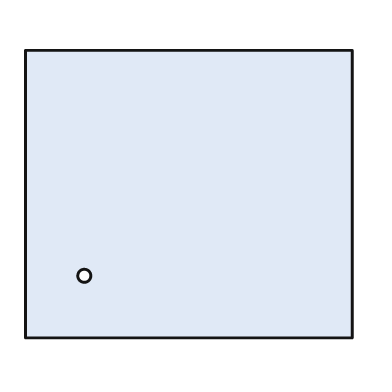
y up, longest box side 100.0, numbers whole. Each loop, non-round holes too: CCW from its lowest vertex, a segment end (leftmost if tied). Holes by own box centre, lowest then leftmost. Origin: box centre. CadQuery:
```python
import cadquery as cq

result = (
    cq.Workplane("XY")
    .moveTo(-50.0, -44.0)
    .lineTo(50.0, -44.0)
    .lineTo(50.0, 44.0)
    .lineTo(-50.0, 44.0)
    .close()
    .moveTo(-32.0, -25.0)
    .circle(2.0)
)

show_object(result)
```